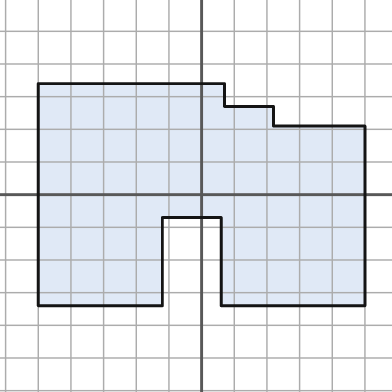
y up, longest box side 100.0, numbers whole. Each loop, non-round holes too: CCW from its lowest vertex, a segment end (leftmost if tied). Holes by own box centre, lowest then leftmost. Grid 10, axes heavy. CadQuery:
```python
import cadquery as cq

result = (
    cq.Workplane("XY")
    .moveTo(-50.0, -34.0)
    .lineTo(-12.0, -34.0)
    .lineTo(-12.0, -7.0)
    .lineTo(6.0, -7.0)
    .lineTo(6.0, -34.0)
    .lineTo(50.0, -34.0)
    .lineTo(50.0, 21.0)
    .lineTo(22.0, 21.0)
    .lineTo(22.0, 27.0)
    .lineTo(7.0, 27.0)
    .lineTo(7.0, 34.0)
    .lineTo(-50.0, 34.0)
    .close()
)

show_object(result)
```